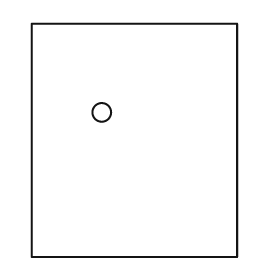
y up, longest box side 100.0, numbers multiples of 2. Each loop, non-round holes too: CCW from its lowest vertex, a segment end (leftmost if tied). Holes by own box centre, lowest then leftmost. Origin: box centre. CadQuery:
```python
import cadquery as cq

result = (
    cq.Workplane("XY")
    .moveTo(-44.0, -50.0)
    .lineTo(44.0, -50.0)
    .lineTo(44.0, 50.0)
    .lineTo(-44.0, 50.0)
    .close()
    .moveTo(-14.0, 12.0)
    .circle(4.0)
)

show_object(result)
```